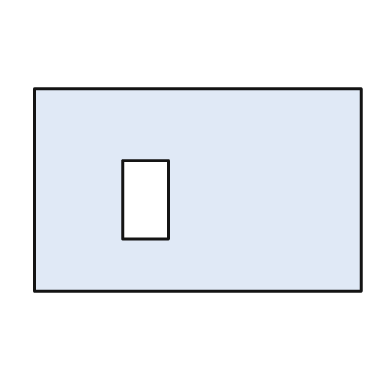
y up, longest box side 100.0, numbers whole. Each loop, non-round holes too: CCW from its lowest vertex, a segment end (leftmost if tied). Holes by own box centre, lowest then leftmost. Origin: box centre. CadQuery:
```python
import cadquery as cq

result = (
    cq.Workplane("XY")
    .moveTo(-50.0, -31.0)
    .lineTo(50.0, -31.0)
    .lineTo(50.0, 31.0)
    .lineTo(-50.0, 31.0)
    .close()
    .moveTo(-23.0, -15.0)
    .lineTo(-9.0, -15.0)
    .lineTo(-9.0, 9.0)
    .lineTo(-23.0, 9.0)
    .close()
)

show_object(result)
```